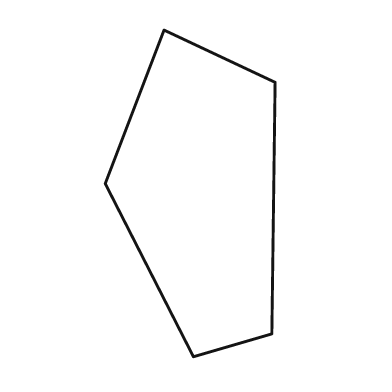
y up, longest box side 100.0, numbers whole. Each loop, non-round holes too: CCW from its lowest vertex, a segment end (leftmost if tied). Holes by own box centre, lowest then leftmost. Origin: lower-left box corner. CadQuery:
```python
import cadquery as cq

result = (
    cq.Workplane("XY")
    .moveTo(27.0, 0.0)
    .lineTo(51.0, 7.0)
    .lineTo(52.0, 84.0)
    .lineTo(18.0, 100.0)
    .lineTo(0.0, 53.0)
    .close()
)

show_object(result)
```